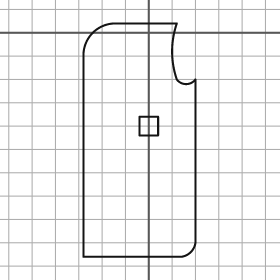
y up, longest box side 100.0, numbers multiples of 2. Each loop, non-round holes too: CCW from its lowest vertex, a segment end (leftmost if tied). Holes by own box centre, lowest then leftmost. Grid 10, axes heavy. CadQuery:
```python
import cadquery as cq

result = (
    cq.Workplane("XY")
    .moveTo(-28.0, -96.0)
    .lineTo(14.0, -96.0)
    .threePointArc((18.0, -94.0), (20.0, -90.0))
    .lineTo(20.0, -20.0)
    .threePointArc((16.0, -22.0), (12.0, -20.0))
    .threePointArc((10.0, -8.0), (12.0, 4.0))
    .lineTo(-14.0, 4.0)
    .threePointArc((-24.0, 0.0), (-28.0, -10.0))
    .close()
    .moveTo(-4.0, -44.0)
    .lineTo(4.0, -44.0)
    .lineTo(4.0, -36.0)
    .lineTo(-4.0, -36.0)
    .close()
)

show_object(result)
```